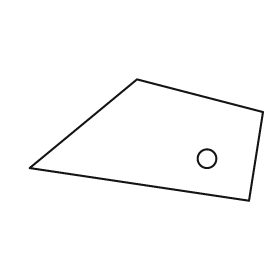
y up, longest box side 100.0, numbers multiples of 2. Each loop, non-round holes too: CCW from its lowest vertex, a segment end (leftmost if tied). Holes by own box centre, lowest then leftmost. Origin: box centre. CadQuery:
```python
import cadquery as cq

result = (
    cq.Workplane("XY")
    .moveTo(44.0, -26.0)
    .lineTo(50.0, 12.0)
    .lineTo(-4.0, 26.0)
    .lineTo(-50.0, -12.0)
    .close()
    .moveTo(26.0, -8.0)
    .circle(4.0)
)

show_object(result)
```